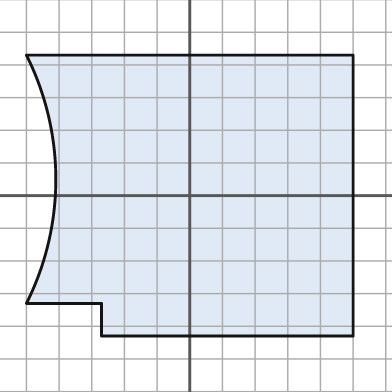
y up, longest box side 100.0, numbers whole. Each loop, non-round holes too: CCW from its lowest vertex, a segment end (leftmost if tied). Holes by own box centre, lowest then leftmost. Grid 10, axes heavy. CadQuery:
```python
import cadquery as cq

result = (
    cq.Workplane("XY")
    .moveTo(-27.0, -43.0)
    .lineTo(50.0, -43.0)
    .lineTo(50.0, 43.0)
    .lineTo(-50.0, 43.0)
    .threePointArc((-41.0, 5.0), (-50.0, -33.0))
    .lineTo(-27.0, -33.0)
    .close()
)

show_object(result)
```